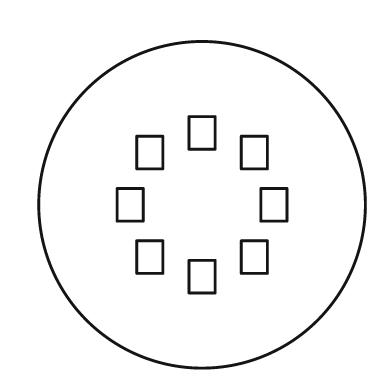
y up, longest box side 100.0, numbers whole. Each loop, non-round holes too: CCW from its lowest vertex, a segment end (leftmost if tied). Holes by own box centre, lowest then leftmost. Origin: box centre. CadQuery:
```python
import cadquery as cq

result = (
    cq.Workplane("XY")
    .moveTo(0.0, 0.0)
    .circle(50.0)
    .moveTo(-4.0, -27.0)
    .lineTo(4.0, -27.0)
    .lineTo(4.0, -17.0)
    .lineTo(-4.0, -17.0)
    .close()
    .moveTo(-20.0, -21.0)
    .lineTo(-12.0, -21.0)
    .lineTo(-12.0, -11.0)
    .lineTo(-20.0, -11.0)
    .close()
    .moveTo(12.0, -21.0)
    .lineTo(20.0, -21.0)
    .lineTo(20.0, -11.0)
    .lineTo(12.0, -11.0)
    .close()
    .moveTo(-26.0, -5.0)
    .lineTo(-18.0, -5.0)
    .lineTo(-18.0, 5.0)
    .lineTo(-26.0, 5.0)
    .close()
    .moveTo(18.0, -5.0)
    .lineTo(26.0, -5.0)
    .lineTo(26.0, 5.0)
    .lineTo(18.0, 5.0)
    .close()
    .moveTo(-20.0, 11.0)
    .lineTo(-12.0, 11.0)
    .lineTo(-12.0, 21.0)
    .lineTo(-20.0, 21.0)
    .close()
    .moveTo(12.0, 11.0)
    .lineTo(20.0, 11.0)
    .lineTo(20.0, 21.0)
    .lineTo(12.0, 21.0)
    .close()
    .moveTo(-4.0, 17.0)
    .lineTo(4.0, 17.0)
    .lineTo(4.0, 27.0)
    .lineTo(-4.0, 27.0)
    .close()
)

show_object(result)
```